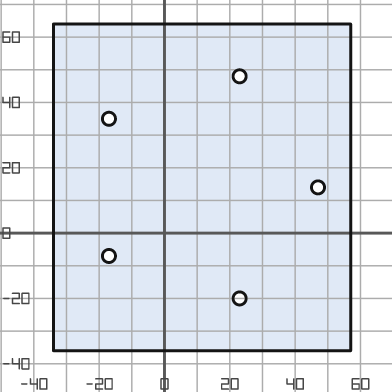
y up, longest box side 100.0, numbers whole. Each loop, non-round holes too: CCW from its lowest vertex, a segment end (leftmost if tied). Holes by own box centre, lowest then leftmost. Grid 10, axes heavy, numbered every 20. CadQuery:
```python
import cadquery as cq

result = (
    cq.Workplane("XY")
    .moveTo(-34.0, -36.0)
    .lineTo(57.0, -36.0)
    .lineTo(57.0, 64.0)
    .lineTo(-34.0, 64.0)
    .close()
    .moveTo(23.0, -20.0)
    .circle(2.0)
    .moveTo(-17.0, -7.0)
    .circle(2.0)
    .moveTo(47.0, 14.0)
    .circle(2.0)
    .moveTo(-17.0, 35.0)
    .circle(2.0)
    .moveTo(23.0, 48.0)
    .circle(2.0)
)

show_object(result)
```